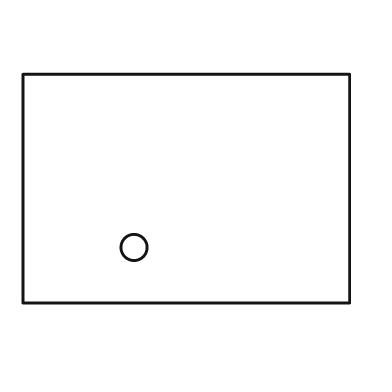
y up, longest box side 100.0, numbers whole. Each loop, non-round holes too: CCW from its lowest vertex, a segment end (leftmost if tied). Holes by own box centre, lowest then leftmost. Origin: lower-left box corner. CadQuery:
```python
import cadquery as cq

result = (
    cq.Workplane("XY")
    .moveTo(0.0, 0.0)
    .lineTo(100.0, 0.0)
    .lineTo(100.0, 70.0)
    .lineTo(0.0, 70.0)
    .close()
    .moveTo(34.0, 17.0)
    .circle(4.0)
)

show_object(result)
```